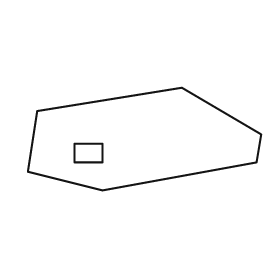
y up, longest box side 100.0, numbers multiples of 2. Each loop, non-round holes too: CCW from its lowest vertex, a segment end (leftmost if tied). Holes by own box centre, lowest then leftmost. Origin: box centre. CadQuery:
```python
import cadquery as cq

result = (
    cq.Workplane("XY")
    .moveTo(-18.0, -22.0)
    .lineTo(48.0, -10.0)
    .lineTo(50.0, 2.0)
    .lineTo(16.0, 22.0)
    .lineTo(-46.0, 12.0)
    .lineTo(-50.0, -14.0)
    .close()
    .moveTo(-30.0, -10.0)
    .lineTo(-18.0, -10.0)
    .lineTo(-18.0, -2.0)
    .lineTo(-30.0, -2.0)
    .close()
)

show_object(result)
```